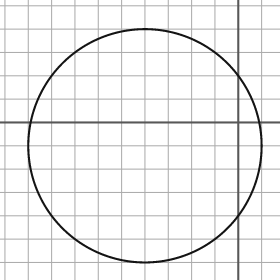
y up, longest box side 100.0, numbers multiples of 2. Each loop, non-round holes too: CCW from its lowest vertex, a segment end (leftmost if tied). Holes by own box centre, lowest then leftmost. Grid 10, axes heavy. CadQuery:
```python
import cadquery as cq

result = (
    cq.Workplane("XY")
    .moveTo(-40.0, -10.0)
    .circle(50.0)
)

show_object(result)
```